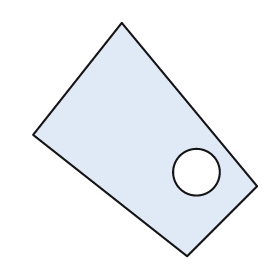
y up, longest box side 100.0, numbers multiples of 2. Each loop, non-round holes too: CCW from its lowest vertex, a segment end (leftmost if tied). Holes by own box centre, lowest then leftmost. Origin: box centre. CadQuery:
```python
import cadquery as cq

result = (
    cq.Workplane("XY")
    .moveTo(18.0, -50.0)
    .lineTo(48.0, -20.0)
    .lineTo(-10.0, 50.0)
    .lineTo(-48.0, 2.0)
    .close()
    .moveTo(22.0, -14.0)
    .circle(10.0)
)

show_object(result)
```